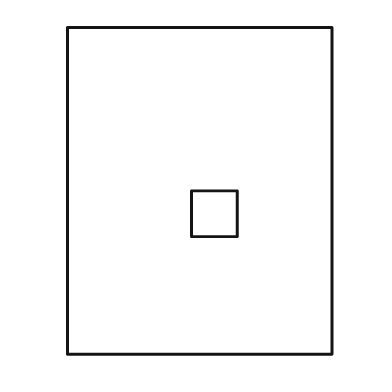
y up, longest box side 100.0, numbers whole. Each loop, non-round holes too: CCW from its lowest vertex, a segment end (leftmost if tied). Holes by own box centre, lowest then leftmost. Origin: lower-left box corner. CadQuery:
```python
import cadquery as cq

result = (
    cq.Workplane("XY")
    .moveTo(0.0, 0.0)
    .lineTo(81.0, 0.0)
    .lineTo(81.0, 100.0)
    .lineTo(0.0, 100.0)
    .close()
    .moveTo(38.0, 36.0)
    .lineTo(52.0, 36.0)
    .lineTo(52.0, 50.0)
    .lineTo(38.0, 50.0)
    .close()
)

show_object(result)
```